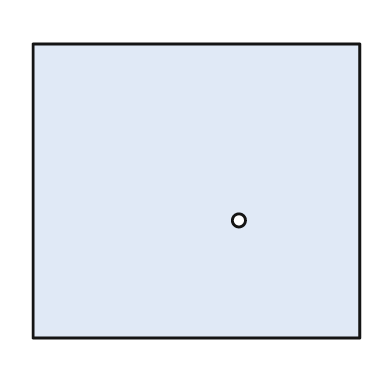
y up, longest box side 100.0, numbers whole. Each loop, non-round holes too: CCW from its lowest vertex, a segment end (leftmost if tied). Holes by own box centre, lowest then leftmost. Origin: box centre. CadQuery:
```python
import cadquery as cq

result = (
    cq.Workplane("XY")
    .moveTo(-50.0, -45.0)
    .lineTo(50.0, -45.0)
    .lineTo(50.0, 45.0)
    .lineTo(-50.0, 45.0)
    .close()
    .moveTo(13.0, -9.0)
    .circle(2.0)
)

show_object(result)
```